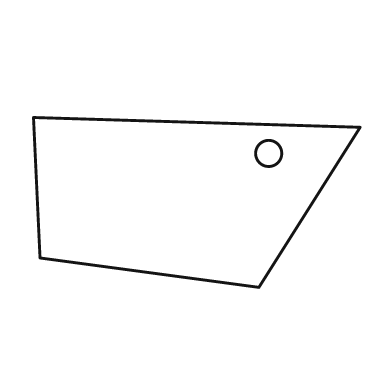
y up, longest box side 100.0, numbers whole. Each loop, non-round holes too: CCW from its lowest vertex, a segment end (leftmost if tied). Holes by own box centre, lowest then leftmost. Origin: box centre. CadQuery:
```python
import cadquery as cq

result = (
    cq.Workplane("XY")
    .moveTo(19.0, -26.0)
    .lineTo(50.0, 23.0)
    .lineTo(-50.0, 26.0)
    .lineTo(-48.0, -17.0)
    .close()
    .moveTo(22.0, 15.0)
    .circle(4.0)
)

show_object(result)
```